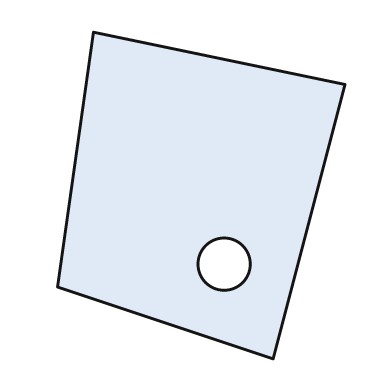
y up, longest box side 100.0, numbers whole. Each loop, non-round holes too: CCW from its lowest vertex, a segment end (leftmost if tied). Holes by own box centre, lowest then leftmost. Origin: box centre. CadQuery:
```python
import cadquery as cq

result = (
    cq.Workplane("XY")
    .moveTo(22.0, -50.0)
    .lineTo(44.0, 34.0)
    .lineTo(-33.0, 50.0)
    .lineTo(-44.0, -28.0)
    .close()
    .moveTo(7.0, -21.0)
    .circle(8.0)
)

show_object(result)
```